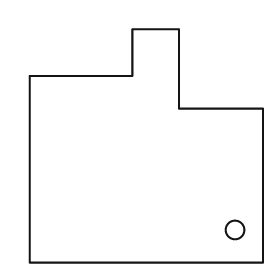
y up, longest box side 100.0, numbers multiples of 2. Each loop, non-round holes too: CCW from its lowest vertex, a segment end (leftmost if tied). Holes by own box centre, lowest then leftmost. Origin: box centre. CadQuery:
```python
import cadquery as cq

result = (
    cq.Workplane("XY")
    .moveTo(-50.0, -50.0)
    .lineTo(50.0, -50.0)
    .lineTo(50.0, 16.0)
    .lineTo(14.0, 16.0)
    .lineTo(14.0, 50.0)
    .lineTo(-6.0, 50.0)
    .lineTo(-6.0, 30.0)
    .lineTo(-50.0, 30.0)
    .close()
    .moveTo(38.0, -36.0)
    .circle(4.0)
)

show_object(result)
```